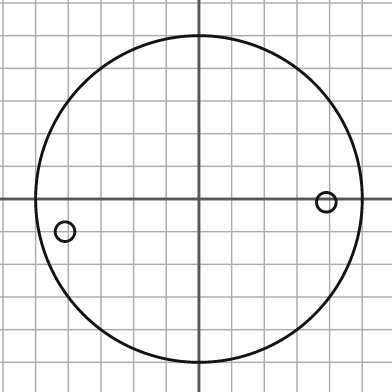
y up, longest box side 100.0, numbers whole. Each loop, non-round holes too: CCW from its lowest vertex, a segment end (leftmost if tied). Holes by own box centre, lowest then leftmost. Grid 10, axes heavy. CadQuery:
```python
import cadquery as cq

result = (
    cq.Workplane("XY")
    .moveTo(0.0, 0.0)
    .circle(50.0)
    .moveTo(-41.0, -10.0)
    .circle(3.0)
    .moveTo(39.0, -1.0)
    .circle(3.0)
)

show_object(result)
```